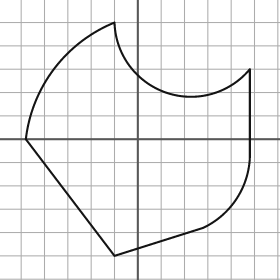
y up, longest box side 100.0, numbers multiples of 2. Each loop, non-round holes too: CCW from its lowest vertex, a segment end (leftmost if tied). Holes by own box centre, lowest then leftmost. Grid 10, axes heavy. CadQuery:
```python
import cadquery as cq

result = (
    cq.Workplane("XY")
    .moveTo(-10.0, -50.0)
    .lineTo(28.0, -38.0)
    .threePointArc((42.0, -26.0), (48.0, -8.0))
    .lineTo(48.0, 30.0)
    .threePointArc((12.0, 20.0), (-10.0, 50.0))
    .threePointArc((-36.0, 30.0), (-48.0, 0.0))
    .close()
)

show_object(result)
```